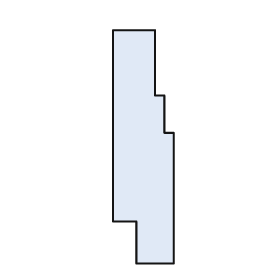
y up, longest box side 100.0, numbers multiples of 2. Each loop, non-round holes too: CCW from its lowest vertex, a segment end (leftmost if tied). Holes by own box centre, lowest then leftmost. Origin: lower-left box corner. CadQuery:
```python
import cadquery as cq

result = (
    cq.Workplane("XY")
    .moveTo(10.0, 0.0)
    .lineTo(26.0, 0.0)
    .lineTo(26.0, 56.0)
    .lineTo(22.0, 56.0)
    .lineTo(22.0, 72.0)
    .lineTo(18.0, 72.0)
    .lineTo(18.0, 100.0)
    .lineTo(0.0, 100.0)
    .lineTo(0.0, 18.0)
    .lineTo(10.0, 18.0)
    .close()
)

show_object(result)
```